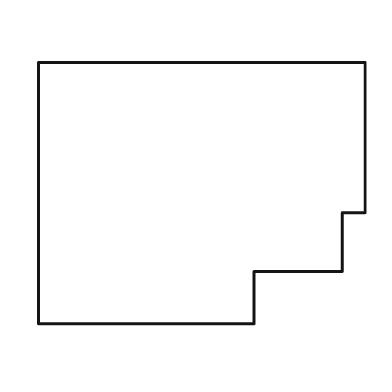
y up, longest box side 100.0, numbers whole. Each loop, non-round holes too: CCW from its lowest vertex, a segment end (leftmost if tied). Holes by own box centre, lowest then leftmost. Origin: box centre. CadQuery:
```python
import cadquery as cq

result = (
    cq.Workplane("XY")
    .moveTo(-50.0, -40.0)
    .lineTo(16.0, -40.0)
    .lineTo(16.0, -24.0)
    .lineTo(43.0, -24.0)
    .lineTo(43.0, -6.0)
    .lineTo(50.0, -6.0)
    .lineTo(50.0, 40.0)
    .lineTo(-50.0, 40.0)
    .close()
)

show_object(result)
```